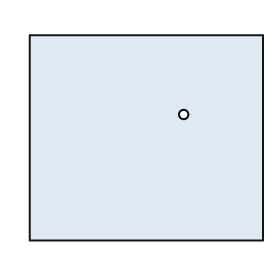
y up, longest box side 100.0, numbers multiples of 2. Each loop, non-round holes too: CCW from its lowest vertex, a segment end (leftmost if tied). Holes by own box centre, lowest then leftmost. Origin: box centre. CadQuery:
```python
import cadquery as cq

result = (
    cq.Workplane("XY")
    .moveTo(-50.0, -44.0)
    .lineTo(50.0, -44.0)
    .lineTo(50.0, 44.0)
    .lineTo(-50.0, 44.0)
    .close()
    .moveTo(16.0, 10.0)
    .circle(2.0)
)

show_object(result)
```